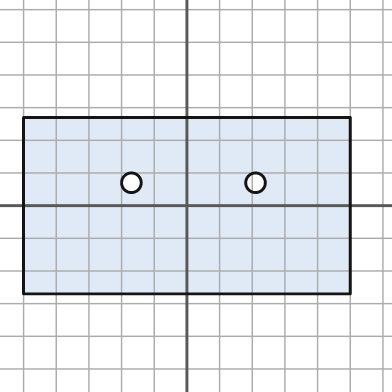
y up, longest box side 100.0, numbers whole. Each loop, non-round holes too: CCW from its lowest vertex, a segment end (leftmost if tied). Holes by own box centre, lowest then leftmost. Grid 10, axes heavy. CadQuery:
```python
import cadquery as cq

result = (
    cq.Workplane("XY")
    .moveTo(-50.0, -27.0)
    .lineTo(50.0, -27.0)
    .lineTo(50.0, 27.0)
    .lineTo(-50.0, 27.0)
    .close()
    .moveTo(-17.0, 7.0)
    .circle(3.0)
    .moveTo(21.0, 7.0)
    .circle(3.0)
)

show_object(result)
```